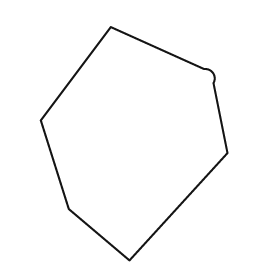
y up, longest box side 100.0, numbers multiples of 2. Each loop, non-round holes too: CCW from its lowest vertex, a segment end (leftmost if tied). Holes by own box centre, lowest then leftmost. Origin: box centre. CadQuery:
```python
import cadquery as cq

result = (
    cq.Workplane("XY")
    .moveTo(-2.0, -50.0)
    .lineTo(40.0, -4.0)
    .lineTo(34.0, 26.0)
    .threePointArc((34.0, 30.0), (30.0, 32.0))
    .lineTo(-10.0, 50.0)
    .lineTo(-40.0, 10.0)
    .lineTo(-28.0, -28.0)
    .close()
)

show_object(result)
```